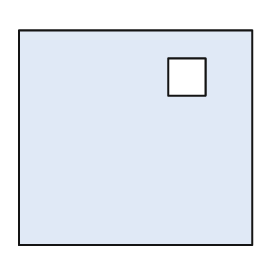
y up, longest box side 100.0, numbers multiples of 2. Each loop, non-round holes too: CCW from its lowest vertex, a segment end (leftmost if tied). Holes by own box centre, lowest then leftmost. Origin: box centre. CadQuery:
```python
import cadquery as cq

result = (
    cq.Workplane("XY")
    .moveTo(-50.0, -46.0)
    .lineTo(50.0, -46.0)
    .lineTo(50.0, 46.0)
    .lineTo(-50.0, 46.0)
    .close()
    .moveTo(14.0, 18.0)
    .lineTo(30.0, 18.0)
    .lineTo(30.0, 34.0)
    .lineTo(14.0, 34.0)
    .close()
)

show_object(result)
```